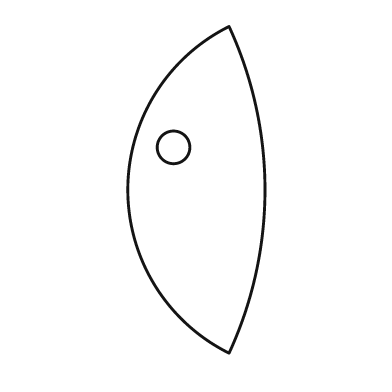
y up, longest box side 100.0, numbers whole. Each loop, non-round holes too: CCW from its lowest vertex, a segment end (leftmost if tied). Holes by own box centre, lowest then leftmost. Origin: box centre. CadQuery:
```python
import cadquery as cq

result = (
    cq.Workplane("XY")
    .moveTo(10.0, -50.0)
    .threePointArc((21.0, 0.0), (10.0, 50.0))
    .threePointArc((-21.0, 0.0), (10.0, -50.0))
    .close()
    .moveTo(-7.0, 13.0)
    .circle(5.0)
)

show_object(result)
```